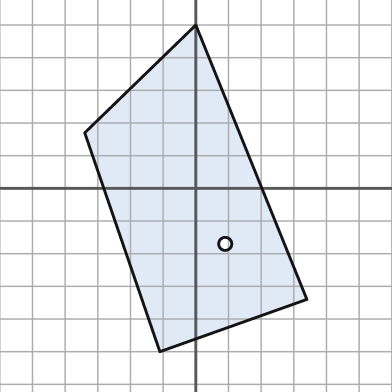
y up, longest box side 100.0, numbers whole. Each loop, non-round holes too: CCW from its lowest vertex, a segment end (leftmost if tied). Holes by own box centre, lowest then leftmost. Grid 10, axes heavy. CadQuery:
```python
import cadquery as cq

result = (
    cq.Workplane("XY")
    .moveTo(-11.0, -50.0)
    .lineTo(34.0, -34.0)
    .lineTo(0.0, 50.0)
    .lineTo(-34.0, 17.0)
    .close()
    .moveTo(9.0, -17.0)
    .circle(2.0)
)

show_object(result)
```